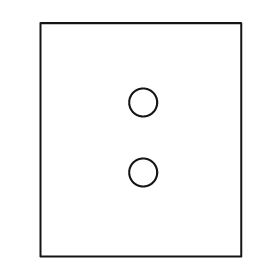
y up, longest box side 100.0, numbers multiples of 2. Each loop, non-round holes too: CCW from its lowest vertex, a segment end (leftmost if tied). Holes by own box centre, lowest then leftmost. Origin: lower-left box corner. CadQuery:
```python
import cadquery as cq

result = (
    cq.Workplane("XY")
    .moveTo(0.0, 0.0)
    .lineTo(86.0, 0.0)
    .lineTo(86.0, 100.0)
    .lineTo(0.0, 100.0)
    .close()
    .moveTo(44.0, 36.0)
    .circle(6.0)
    .moveTo(44.0, 66.0)
    .circle(6.0)
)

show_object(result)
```